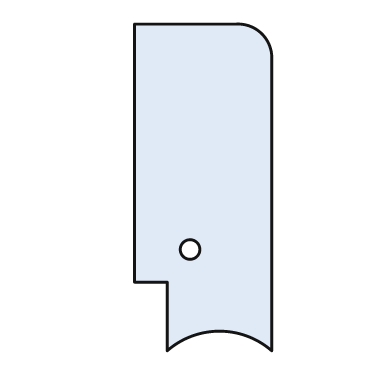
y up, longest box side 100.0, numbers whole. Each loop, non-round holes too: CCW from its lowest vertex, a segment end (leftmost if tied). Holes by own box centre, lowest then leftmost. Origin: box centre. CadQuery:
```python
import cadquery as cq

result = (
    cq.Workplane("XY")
    .moveTo(-11.0, -50.0)
    .threePointArc((5.0, -44.0), (21.0, -50.0))
    .lineTo(21.0, 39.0)
    .threePointArc((18.0, 47.0), (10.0, 50.0))
    .lineTo(-21.0, 50.0)
    .lineTo(-21.0, -29.0)
    .lineTo(-11.0, -29.0)
    .close()
    .moveTo(-4.0, -19.0)
    .circle(3.0)
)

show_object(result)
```